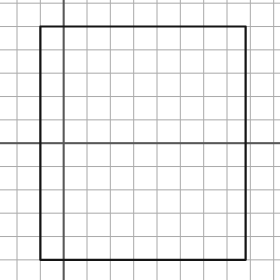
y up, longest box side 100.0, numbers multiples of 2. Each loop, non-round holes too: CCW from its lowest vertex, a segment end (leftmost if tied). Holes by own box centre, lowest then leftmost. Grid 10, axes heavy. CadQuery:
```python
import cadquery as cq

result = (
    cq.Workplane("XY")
    .moveTo(-10.0, -50.0)
    .lineTo(78.0, -50.0)
    .lineTo(78.0, 50.0)
    .lineTo(-10.0, 50.0)
    .close()
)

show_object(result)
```